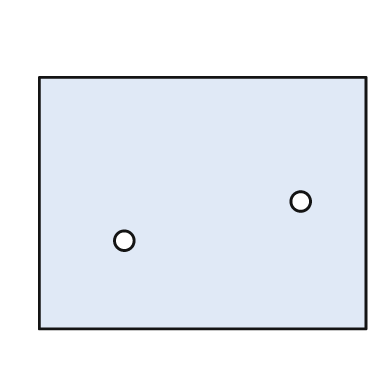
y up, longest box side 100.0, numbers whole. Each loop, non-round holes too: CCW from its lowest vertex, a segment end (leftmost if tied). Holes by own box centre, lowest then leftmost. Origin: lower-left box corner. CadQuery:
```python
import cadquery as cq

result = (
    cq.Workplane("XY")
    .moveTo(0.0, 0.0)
    .lineTo(100.0, 0.0)
    .lineTo(100.0, 77.0)
    .lineTo(0.0, 77.0)
    .close()
    .moveTo(26.0, 27.0)
    .circle(3.0)
    .moveTo(80.0, 39.0)
    .circle(3.0)
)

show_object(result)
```